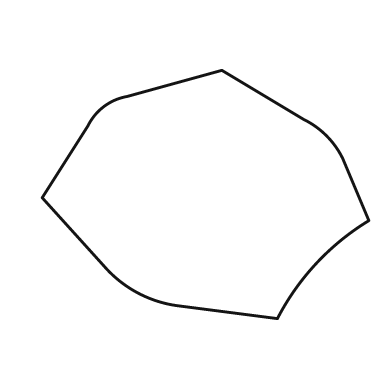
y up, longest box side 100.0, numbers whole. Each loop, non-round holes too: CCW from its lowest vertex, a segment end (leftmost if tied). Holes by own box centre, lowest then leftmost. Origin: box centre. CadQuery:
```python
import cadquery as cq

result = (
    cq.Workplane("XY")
    .moveTo(22.0, -38.0)
    .threePointArc((34.0, -21.0), (50.0, -8.0))
    .lineTo(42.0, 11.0)
    .threePointArc((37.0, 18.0), (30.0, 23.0))
    .lineTo(5.0, 38.0)
    .lineTo(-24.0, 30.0)
    .threePointArc((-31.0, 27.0), (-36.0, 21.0))
    .lineTo(-50.0, -1.0)
    .lineTo(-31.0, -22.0)
    .threePointArc((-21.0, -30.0), (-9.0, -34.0))
    .close()
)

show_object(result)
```